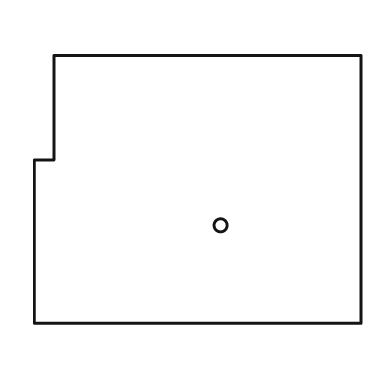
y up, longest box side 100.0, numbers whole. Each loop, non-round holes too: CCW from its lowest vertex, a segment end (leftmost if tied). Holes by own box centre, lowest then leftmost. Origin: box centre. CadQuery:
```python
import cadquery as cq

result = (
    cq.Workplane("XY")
    .moveTo(-50.0, -41.0)
    .lineTo(50.0, -41.0)
    .lineTo(50.0, 41.0)
    .lineTo(-44.0, 41.0)
    .lineTo(-44.0, 9.0)
    .lineTo(-50.0, 9.0)
    .close()
    .moveTo(7.0, -11.0)
    .circle(2.0)
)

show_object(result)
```